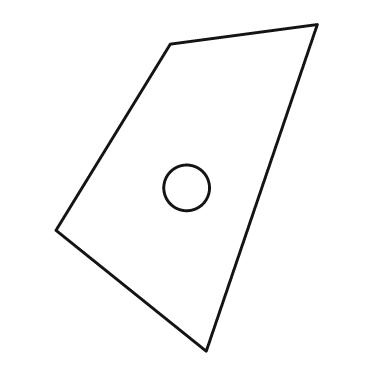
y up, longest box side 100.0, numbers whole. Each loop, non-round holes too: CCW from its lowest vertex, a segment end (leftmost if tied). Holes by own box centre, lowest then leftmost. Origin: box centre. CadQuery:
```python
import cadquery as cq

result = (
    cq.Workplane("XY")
    .moveTo(6.0, -50.0)
    .lineTo(40.0, 50.0)
    .lineTo(-5.0, 44.0)
    .lineTo(-40.0, -13.0)
    .close()
    .moveTo(0.0, 0.0)
    .circle(7.0)
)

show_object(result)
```